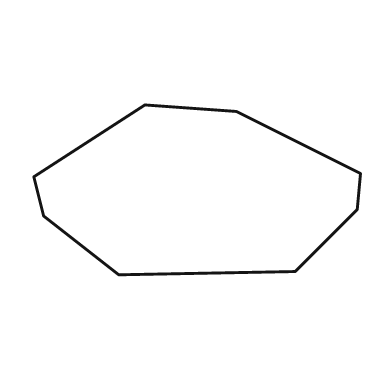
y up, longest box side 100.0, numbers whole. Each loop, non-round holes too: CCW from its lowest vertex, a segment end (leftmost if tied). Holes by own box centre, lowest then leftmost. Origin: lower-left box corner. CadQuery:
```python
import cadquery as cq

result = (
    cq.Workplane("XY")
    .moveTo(26.0, 0.0)
    .lineTo(80.0, 1.0)
    .lineTo(99.0, 20.0)
    .lineTo(100.0, 31.0)
    .lineTo(62.0, 50.0)
    .lineTo(34.0, 52.0)
    .lineTo(0.0, 30.0)
    .lineTo(3.0, 18.0)
    .close()
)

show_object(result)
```